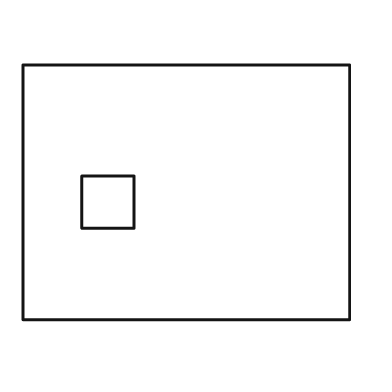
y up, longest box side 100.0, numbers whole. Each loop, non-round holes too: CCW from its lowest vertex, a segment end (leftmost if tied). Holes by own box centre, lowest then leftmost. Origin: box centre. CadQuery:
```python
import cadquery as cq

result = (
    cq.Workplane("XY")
    .moveTo(-50.0, -39.0)
    .lineTo(50.0, -39.0)
    .lineTo(50.0, 39.0)
    .lineTo(-50.0, 39.0)
    .close()
    .moveTo(-32.0, -11.0)
    .lineTo(-16.0, -11.0)
    .lineTo(-16.0, 5.0)
    .lineTo(-32.0, 5.0)
    .close()
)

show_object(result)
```